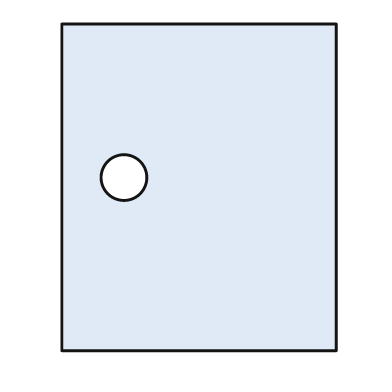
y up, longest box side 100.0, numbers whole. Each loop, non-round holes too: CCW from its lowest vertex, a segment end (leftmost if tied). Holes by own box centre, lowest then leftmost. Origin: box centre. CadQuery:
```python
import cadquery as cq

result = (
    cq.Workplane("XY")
    .moveTo(-42.0, -50.0)
    .lineTo(42.0, -50.0)
    .lineTo(42.0, 50.0)
    .lineTo(-42.0, 50.0)
    .close()
    .moveTo(-23.0, 3.0)
    .circle(7.0)
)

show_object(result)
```